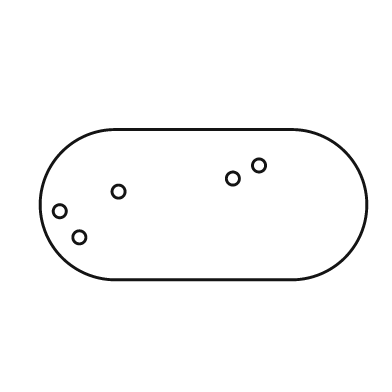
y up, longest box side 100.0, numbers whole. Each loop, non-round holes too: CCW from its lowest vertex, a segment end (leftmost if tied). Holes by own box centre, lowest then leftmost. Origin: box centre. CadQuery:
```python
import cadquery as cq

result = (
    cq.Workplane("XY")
    .moveTo(-27.0, -23.0)
    .lineTo(27.0, -23.0)
    .threePointArc((50.0, 0.0), (27.0, 23.0))
    .lineTo(-27.0, 23.0)
    .threePointArc((-50.0, 0.0), (-27.0, -23.0))
    .close()
    .moveTo(-38.0, -10.0)
    .circle(2.0)
    .moveTo(-44.0, -2.0)
    .circle(2.0)
    .moveTo(-26.0, 4.0)
    .circle(2.0)
    .moveTo(9.0, 8.0)
    .circle(2.0)
    .moveTo(17.0, 12.0)
    .circle(2.0)
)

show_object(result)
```